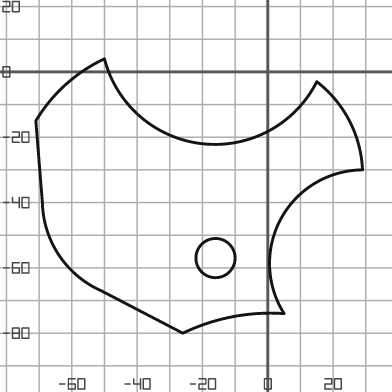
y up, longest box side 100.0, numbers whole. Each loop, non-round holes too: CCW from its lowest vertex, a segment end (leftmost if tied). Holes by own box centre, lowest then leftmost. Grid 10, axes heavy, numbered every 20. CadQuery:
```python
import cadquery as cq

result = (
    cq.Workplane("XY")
    .moveTo(-26.0, -80.0)
    .threePointArc((-11.0, -75.0), (5.0, -74.0))
    .threePointArc((4.0, -45.0), (29.0, -30.0))
    .threePointArc((25.0, -15.0), (15.0, -3.0))
    .threePointArc((-20.0, -22.0), (-50.0, 4.0))
    .threePointArc((-62.0, -4.0), (-71.0, -15.0))
    .lineTo(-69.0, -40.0)
    .threePointArc((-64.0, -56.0), (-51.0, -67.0))
    .close()
    .moveTo(-16.0, -57.0)
    .circle(6.0)
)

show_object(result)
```